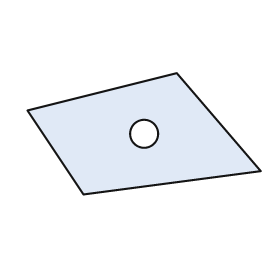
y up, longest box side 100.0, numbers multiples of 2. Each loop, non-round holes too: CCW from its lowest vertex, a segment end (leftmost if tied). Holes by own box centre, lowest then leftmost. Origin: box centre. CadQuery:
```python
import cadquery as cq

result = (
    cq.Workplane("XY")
    .moveTo(-26.0, -26.0)
    .lineTo(50.0, -16.0)
    .lineTo(14.0, 26.0)
    .lineTo(-50.0, 10.0)
    .close()
    .moveTo(0.0, 0.0)
    .circle(6.0)
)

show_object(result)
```